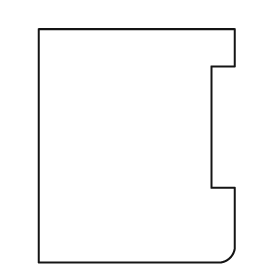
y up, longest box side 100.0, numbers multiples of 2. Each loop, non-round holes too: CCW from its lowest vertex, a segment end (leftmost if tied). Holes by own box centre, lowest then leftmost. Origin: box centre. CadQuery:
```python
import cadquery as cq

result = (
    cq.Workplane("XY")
    .moveTo(-42.0, -50.0)
    .lineTo(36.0, -50.0)
    .threePointArc((40.0, -48.0), (42.0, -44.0))
    .lineTo(42.0, -18.0)
    .lineTo(32.0, -18.0)
    .lineTo(32.0, 34.0)
    .lineTo(42.0, 34.0)
    .lineTo(42.0, 50.0)
    .lineTo(-42.0, 50.0)
    .close()
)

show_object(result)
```